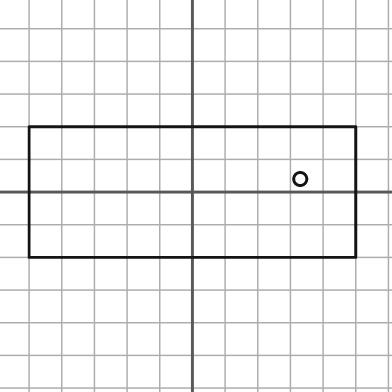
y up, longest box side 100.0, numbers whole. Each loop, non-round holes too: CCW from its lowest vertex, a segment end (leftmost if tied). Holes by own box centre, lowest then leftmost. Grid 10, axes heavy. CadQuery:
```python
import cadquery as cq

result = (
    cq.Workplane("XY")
    .moveTo(-50.0, -20.0)
    .lineTo(50.0, -20.0)
    .lineTo(50.0, 20.0)
    .lineTo(-50.0, 20.0)
    .close()
    .moveTo(33.0, 4.0)
    .circle(2.0)
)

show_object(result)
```